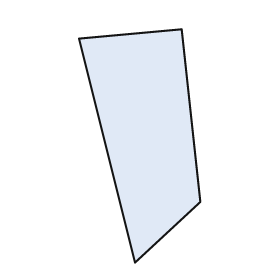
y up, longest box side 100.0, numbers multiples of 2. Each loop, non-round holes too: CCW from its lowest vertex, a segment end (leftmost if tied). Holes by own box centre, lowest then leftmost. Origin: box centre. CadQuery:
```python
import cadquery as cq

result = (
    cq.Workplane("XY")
    .moveTo(-2.0, -50.0)
    .lineTo(26.0, -24.0)
    .lineTo(18.0, 50.0)
    .lineTo(-26.0, 46.0)
    .close()
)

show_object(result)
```